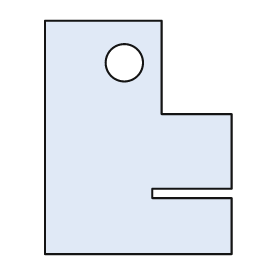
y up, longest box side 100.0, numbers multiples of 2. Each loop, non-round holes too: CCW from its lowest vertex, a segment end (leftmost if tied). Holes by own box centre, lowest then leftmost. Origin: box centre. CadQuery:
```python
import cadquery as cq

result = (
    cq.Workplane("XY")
    .moveTo(-40.0, -50.0)
    .lineTo(40.0, -50.0)
    .lineTo(40.0, -26.0)
    .lineTo(6.0, -26.0)
    .lineTo(6.0, -22.0)
    .lineTo(40.0, -22.0)
    .lineTo(40.0, 10.0)
    .lineTo(10.0, 10.0)
    .lineTo(10.0, 50.0)
    .lineTo(-40.0, 50.0)
    .close()
    .moveTo(-6.0, 32.0)
    .circle(8.0)
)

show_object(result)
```